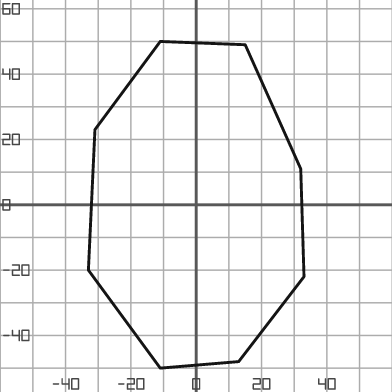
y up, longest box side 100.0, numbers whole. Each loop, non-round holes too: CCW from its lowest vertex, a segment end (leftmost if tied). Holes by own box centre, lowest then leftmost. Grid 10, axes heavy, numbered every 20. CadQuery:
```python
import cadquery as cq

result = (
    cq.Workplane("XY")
    .moveTo(-11.0, -50.0)
    .lineTo(13.0, -48.0)
    .lineTo(33.0, -22.0)
    .lineTo(32.0, 11.0)
    .lineTo(15.0, 49.0)
    .lineTo(-11.0, 50.0)
    .lineTo(-31.0, 23.0)
    .lineTo(-33.0, -20.0)
    .close()
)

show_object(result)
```